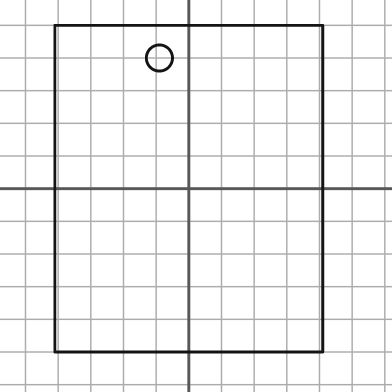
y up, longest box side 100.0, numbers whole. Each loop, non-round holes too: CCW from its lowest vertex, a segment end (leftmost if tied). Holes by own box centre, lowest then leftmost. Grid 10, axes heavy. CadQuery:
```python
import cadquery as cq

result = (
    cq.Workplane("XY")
    .moveTo(-41.0, -50.0)
    .lineTo(41.0, -50.0)
    .lineTo(41.0, 50.0)
    .lineTo(-41.0, 50.0)
    .close()
    .moveTo(-9.0, 40.0)
    .circle(4.0)
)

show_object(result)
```